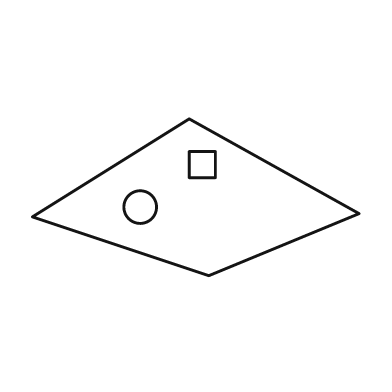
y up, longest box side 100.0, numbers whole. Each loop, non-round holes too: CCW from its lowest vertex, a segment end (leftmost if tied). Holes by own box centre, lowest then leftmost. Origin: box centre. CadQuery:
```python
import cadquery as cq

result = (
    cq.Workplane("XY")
    .moveTo(4.0, -24.0)
    .lineTo(50.0, -5.0)
    .lineTo(-2.0, 24.0)
    .lineTo(-50.0, -6.0)
    .close()
    .moveTo(-17.0, -3.0)
    .circle(5.0)
    .moveTo(-2.0, 6.0)
    .lineTo(6.0, 6.0)
    .lineTo(6.0, 14.0)
    .lineTo(-2.0, 14.0)
    .close()
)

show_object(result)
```